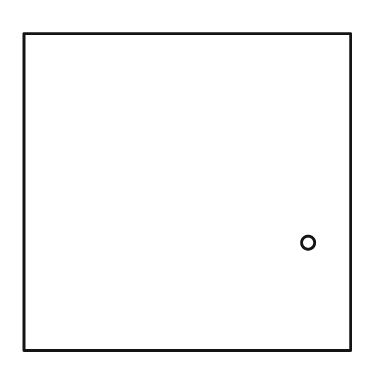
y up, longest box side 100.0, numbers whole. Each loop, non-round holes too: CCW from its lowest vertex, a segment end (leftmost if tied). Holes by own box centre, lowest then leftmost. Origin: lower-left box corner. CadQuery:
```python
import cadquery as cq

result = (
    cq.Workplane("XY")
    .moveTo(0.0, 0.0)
    .lineTo(100.0, 0.0)
    .lineTo(100.0, 97.0)
    .lineTo(0.0, 97.0)
    .close()
    .moveTo(87.0, 33.0)
    .circle(2.0)
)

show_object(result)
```